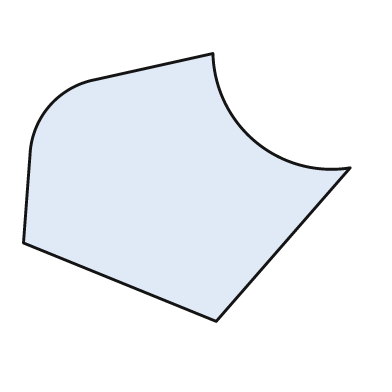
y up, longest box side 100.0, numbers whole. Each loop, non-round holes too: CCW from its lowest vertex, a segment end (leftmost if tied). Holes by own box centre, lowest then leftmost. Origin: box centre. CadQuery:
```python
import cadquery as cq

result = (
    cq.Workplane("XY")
    .moveTo(9.0, -41.0)
    .lineTo(50.0, 6.0)
    .threePointArc((21.0, 14.0), (8.0, 41.0))
    .lineTo(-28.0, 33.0)
    .threePointArc((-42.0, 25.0), (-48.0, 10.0))
    .lineTo(-50.0, -17.0)
    .close()
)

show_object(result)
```